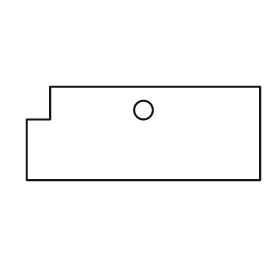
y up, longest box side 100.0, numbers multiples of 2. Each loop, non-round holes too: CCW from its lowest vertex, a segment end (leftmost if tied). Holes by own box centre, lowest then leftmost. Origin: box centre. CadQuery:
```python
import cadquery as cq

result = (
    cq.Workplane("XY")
    .moveTo(-50.0, -20.0)
    .lineTo(50.0, -20.0)
    .lineTo(50.0, 20.0)
    .lineTo(-40.0, 20.0)
    .lineTo(-40.0, 6.0)
    .lineTo(-50.0, 6.0)
    .close()
    .moveTo(0.0, 10.0)
    .circle(4.0)
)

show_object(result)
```